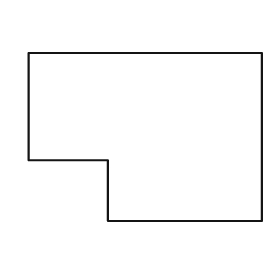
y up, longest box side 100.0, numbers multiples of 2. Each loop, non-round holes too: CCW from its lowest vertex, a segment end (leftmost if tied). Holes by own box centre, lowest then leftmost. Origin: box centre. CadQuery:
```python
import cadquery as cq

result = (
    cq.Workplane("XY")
    .moveTo(-16.0, -36.0)
    .lineTo(50.0, -36.0)
    .lineTo(50.0, 36.0)
    .lineTo(-50.0, 36.0)
    .lineTo(-50.0, -10.0)
    .lineTo(-16.0, -10.0)
    .close()
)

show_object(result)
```